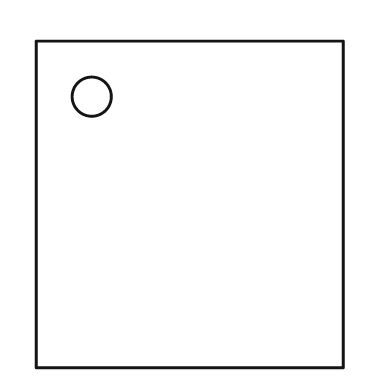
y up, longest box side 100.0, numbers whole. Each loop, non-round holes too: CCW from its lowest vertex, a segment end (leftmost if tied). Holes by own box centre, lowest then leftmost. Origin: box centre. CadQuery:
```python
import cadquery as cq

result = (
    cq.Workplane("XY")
    .moveTo(-47.0, -50.0)
    .lineTo(47.0, -50.0)
    .lineTo(47.0, 50.0)
    .lineTo(-47.0, 50.0)
    .close()
    .moveTo(-30.0, 33.0)
    .circle(6.0)
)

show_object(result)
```